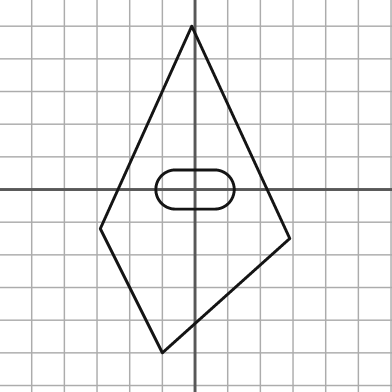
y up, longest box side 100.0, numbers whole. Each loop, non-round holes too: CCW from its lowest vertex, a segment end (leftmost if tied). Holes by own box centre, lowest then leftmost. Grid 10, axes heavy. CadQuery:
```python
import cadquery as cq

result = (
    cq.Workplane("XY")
    .moveTo(-10.0, -50.0)
    .lineTo(29.0, -15.0)
    .lineTo(-1.0, 50.0)
    .lineTo(-29.0, -12.0)
    .close()
    .moveTo(-6.0, -6.0)
    .lineTo(6.0, -6.0)
    .threePointArc((12.0, 0.0), (6.0, 6.0))
    .lineTo(-6.0, 6.0)
    .threePointArc((-12.0, 0.0), (-6.0, -6.0))
    .close()
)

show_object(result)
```